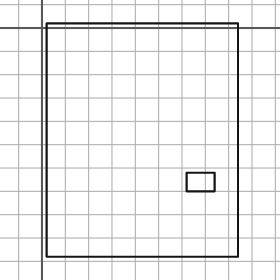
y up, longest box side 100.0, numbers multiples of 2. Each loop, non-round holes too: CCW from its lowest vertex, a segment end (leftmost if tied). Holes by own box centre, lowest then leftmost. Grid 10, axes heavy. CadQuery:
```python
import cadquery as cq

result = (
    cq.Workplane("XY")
    .moveTo(2.0, -98.0)
    .lineTo(84.0, -98.0)
    .lineTo(84.0, 2.0)
    .lineTo(2.0, 2.0)
    .close()
    .moveTo(62.0, -70.0)
    .lineTo(74.0, -70.0)
    .lineTo(74.0, -62.0)
    .lineTo(62.0, -62.0)
    .close()
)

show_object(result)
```